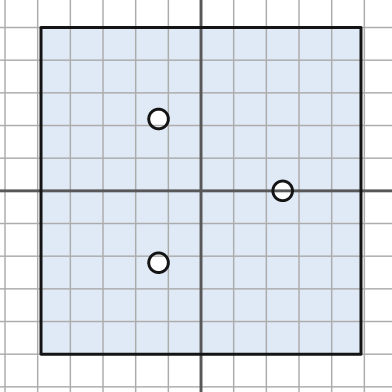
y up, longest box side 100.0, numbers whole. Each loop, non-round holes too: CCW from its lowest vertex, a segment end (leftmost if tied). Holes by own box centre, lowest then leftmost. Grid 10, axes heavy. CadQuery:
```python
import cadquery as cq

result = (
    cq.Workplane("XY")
    .moveTo(-49.0, -50.0)
    .lineTo(49.0, -50.0)
    .lineTo(49.0, 50.0)
    .lineTo(-49.0, 50.0)
    .close()
    .moveTo(-13.0, -22.0)
    .circle(3.0)
    .moveTo(25.0, 0.0)
    .circle(3.0)
    .moveTo(-13.0, 22.0)
    .circle(3.0)
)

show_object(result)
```